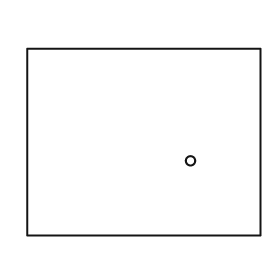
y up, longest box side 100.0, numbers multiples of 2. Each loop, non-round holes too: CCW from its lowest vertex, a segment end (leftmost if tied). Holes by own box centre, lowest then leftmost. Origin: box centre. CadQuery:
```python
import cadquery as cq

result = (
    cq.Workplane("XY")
    .moveTo(-50.0, -40.0)
    .lineTo(50.0, -40.0)
    .lineTo(50.0, 40.0)
    .lineTo(-50.0, 40.0)
    .close()
    .moveTo(20.0, -8.0)
    .circle(2.0)
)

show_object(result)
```